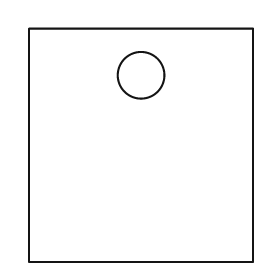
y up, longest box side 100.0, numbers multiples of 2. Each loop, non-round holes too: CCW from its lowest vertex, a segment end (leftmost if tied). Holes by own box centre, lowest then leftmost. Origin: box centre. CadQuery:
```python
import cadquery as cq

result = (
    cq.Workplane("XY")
    .moveTo(-48.0, -50.0)
    .lineTo(48.0, -50.0)
    .lineTo(48.0, 50.0)
    .lineTo(-48.0, 50.0)
    .close()
    .moveTo(0.0, 30.0)
    .circle(10.0)
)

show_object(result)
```